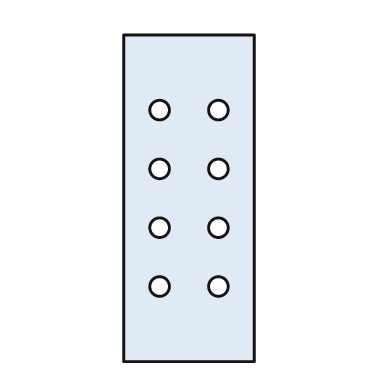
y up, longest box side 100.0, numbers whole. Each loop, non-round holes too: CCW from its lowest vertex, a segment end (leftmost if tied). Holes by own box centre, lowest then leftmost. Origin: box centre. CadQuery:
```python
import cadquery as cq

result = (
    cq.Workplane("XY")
    .moveTo(-20.0, -50.0)
    .lineTo(20.0, -50.0)
    .lineTo(20.0, 50.0)
    .lineTo(-20.0, 50.0)
    .close()
    .moveTo(-9.0, -27.0)
    .circle(3.0)
    .moveTo(9.0, -27.0)
    .circle(3.0)
    .moveTo(-9.0, -9.0)
    .circle(3.0)
    .moveTo(9.0, -9.0)
    .circle(3.0)
    .moveTo(-9.0, 9.0)
    .circle(3.0)
    .moveTo(9.0, 9.0)
    .circle(3.0)
    .moveTo(-9.0, 27.0)
    .circle(3.0)
    .moveTo(9.0, 27.0)
    .circle(3.0)
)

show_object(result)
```